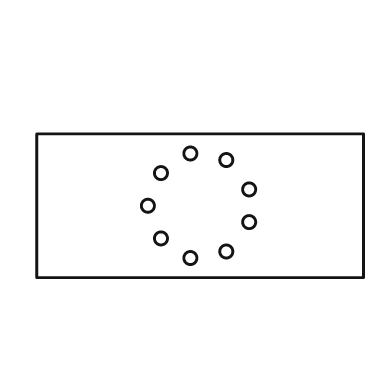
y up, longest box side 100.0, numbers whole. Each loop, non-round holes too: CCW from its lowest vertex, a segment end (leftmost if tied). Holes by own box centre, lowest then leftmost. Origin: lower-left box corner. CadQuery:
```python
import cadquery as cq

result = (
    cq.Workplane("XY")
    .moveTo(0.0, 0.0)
    .lineTo(100.0, 0.0)
    .lineTo(100.0, 44.0)
    .lineTo(0.0, 44.0)
    .close()
    .moveTo(47.0, 6.0)
    .circle(2.0)
    .moveTo(58.0, 8.0)
    .circle(2.0)
    .moveTo(38.0, 12.0)
    .circle(2.0)
    .moveTo(65.0, 17.0)
    .circle(2.0)
    .moveTo(34.0, 22.0)
    .circle(2.0)
    .moveTo(65.0, 27.0)
    .circle(2.0)
    .moveTo(38.0, 32.0)
    .circle(2.0)
    .moveTo(58.0, 36.0)
    .circle(2.0)
    .moveTo(47.0, 38.0)
    .circle(2.0)
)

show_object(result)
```